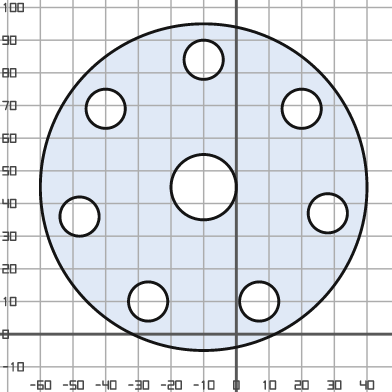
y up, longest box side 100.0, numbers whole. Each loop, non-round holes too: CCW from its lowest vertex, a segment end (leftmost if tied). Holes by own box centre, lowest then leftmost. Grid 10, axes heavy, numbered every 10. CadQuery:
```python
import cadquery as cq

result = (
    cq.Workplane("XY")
    .moveTo(-10.0, 45.0)
    .circle(50.0)
    .moveTo(-27.0, 10.0)
    .circle(6.0)
    .moveTo(7.0, 10.0)
    .circle(6.0)
    .moveTo(-48.0, 36.0)
    .circle(6.0)
    .moveTo(28.0, 37.0)
    .circle(6.0)
    .moveTo(-10.0, 45.0)
    .circle(10.0)
    .moveTo(-40.0, 69.0)
    .circle(6.0)
    .moveTo(20.0, 69.0)
    .circle(6.0)
    .moveTo(-10.0, 84.0)
    .circle(6.0)
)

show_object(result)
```